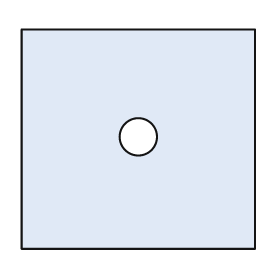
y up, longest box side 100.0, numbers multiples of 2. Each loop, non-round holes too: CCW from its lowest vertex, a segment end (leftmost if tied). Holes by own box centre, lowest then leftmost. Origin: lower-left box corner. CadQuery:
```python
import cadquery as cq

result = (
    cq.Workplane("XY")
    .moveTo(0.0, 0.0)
    .lineTo(100.0, 0.0)
    .lineTo(100.0, 94.0)
    .lineTo(0.0, 94.0)
    .close()
    .moveTo(50.0, 48.0)
    .circle(8.0)
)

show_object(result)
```